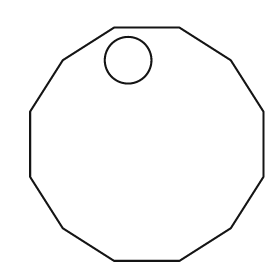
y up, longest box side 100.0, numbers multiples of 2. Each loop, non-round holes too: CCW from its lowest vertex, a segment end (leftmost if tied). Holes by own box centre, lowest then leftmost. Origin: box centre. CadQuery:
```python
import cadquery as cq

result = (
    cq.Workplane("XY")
    .moveTo(-14.0, -50.0)
    .lineTo(14.0, -50.0)
    .lineTo(36.0, -36.0)
    .lineTo(50.0, -14.0)
    .lineTo(50.0, 14.0)
    .lineTo(36.0, 36.0)
    .lineTo(14.0, 50.0)
    .lineTo(-14.0, 50.0)
    .lineTo(-36.0, 36.0)
    .lineTo(-50.0, 14.0)
    .lineTo(-50.0, -14.0)
    .lineTo(-36.0, -36.0)
    .close()
    .moveTo(-8.0, 36.0)
    .circle(10.0)
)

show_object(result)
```